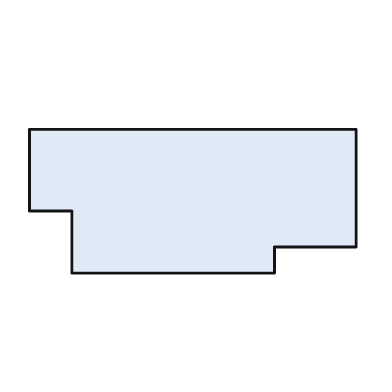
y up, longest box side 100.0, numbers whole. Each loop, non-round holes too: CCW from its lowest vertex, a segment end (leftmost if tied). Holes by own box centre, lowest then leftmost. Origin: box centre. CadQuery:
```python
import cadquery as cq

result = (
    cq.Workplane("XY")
    .moveTo(-37.0, -22.0)
    .lineTo(25.0, -22.0)
    .lineTo(25.0, -14.0)
    .lineTo(50.0, -14.0)
    .lineTo(50.0, 22.0)
    .lineTo(-50.0, 22.0)
    .lineTo(-50.0, -3.0)
    .lineTo(-37.0, -3.0)
    .close()
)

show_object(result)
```